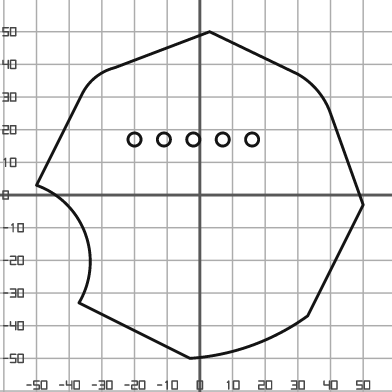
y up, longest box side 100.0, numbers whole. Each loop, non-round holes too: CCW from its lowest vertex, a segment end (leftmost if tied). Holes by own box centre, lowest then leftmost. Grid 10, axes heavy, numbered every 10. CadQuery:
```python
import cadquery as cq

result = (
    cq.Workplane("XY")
    .moveTo(-3.0, -50.0)
    .threePointArc((16.0, -46.0), (33.0, -37.0))
    .lineTo(50.0, -3.0)
    .lineTo(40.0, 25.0)
    .threePointArc((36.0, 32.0), (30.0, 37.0))
    .lineTo(3.0, 50.0)
    .lineTo(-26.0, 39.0)
    .threePointArc((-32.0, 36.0), (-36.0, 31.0))
    .lineTo(-50.0, 3.0)
    .threePointArc((-35.0, -12.0), (-37.0, -33.0))
    .close()
    .moveTo(-20.0, 17.0)
    .circle(2.0)
    .moveTo(-11.0, 17.0)
    .circle(2.0)
    .moveTo(-2.0, 17.0)
    .circle(2.0)
    .moveTo(7.0, 17.0)
    .circle(2.0)
    .moveTo(16.0, 17.0)
    .circle(2.0)
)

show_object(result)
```